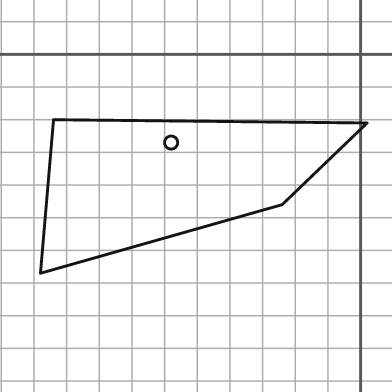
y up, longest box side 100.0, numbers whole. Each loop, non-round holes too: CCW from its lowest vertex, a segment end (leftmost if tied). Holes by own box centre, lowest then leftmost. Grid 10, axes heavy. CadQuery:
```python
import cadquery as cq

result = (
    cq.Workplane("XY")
    .moveTo(-98.0, -67.0)
    .lineTo(-24.0, -46.0)
    .lineTo(2.0, -21.0)
    .lineTo(-94.0, -20.0)
    .close()
    .moveTo(-58.0, -27.0)
    .circle(2.0)
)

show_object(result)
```